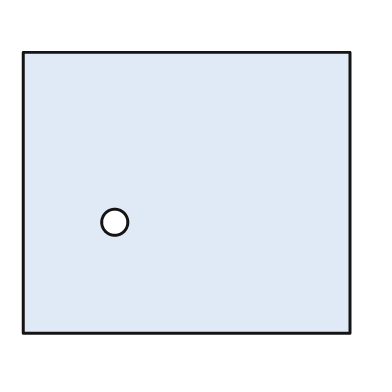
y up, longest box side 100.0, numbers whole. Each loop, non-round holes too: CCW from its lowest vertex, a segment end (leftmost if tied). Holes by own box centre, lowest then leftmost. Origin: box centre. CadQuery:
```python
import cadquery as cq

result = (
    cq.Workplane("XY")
    .moveTo(-50.0, -43.0)
    .lineTo(50.0, -43.0)
    .lineTo(50.0, 43.0)
    .lineTo(-50.0, 43.0)
    .close()
    .moveTo(-22.0, -9.0)
    .circle(4.0)
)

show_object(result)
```